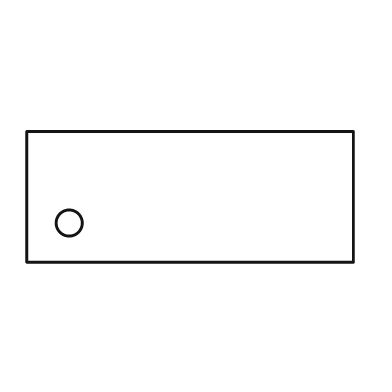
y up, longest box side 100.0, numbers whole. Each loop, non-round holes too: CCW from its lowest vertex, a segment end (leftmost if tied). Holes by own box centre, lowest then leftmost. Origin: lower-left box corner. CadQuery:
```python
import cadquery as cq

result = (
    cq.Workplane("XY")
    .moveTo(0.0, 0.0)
    .lineTo(100.0, 0.0)
    .lineTo(100.0, 40.0)
    .lineTo(0.0, 40.0)
    .close()
    .moveTo(13.0, 12.0)
    .circle(4.0)
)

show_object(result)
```